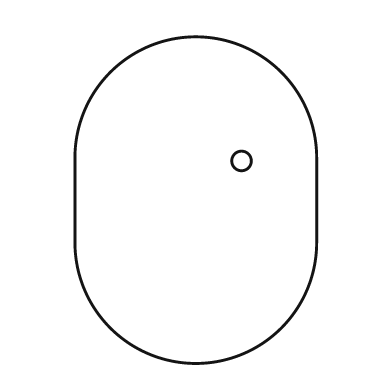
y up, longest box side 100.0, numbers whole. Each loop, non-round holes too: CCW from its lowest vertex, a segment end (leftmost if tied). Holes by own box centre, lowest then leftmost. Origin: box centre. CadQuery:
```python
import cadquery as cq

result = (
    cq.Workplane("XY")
    .moveTo(-37.0, -13.0)
    .threePointArc((0.0, -50.0), (37.0, -13.0))
    .lineTo(37.0, 13.0)
    .threePointArc((0.0, 50.0), (-37.0, 13.0))
    .close()
    .moveTo(14.0, 12.0)
    .circle(3.0)
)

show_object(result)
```